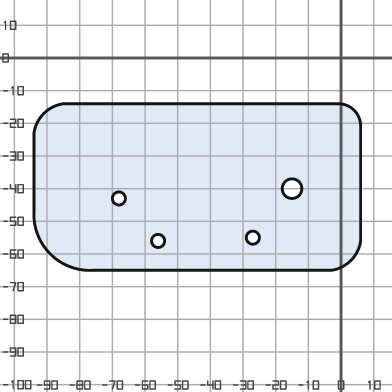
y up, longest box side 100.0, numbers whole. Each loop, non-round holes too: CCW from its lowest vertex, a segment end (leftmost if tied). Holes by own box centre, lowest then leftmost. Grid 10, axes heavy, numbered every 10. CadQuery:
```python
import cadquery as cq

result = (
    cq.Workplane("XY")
    .moveTo(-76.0, -65.0)
    .lineTo(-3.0, -65.0)
    .threePointArc((3.0, -62.0), (6.0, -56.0))
    .lineTo(6.0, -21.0)
    .threePointArc((4.0, -16.0), (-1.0, -14.0))
    .lineTo(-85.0, -14.0)
    .threePointArc((-91.0, -17.0), (-94.0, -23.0))
    .lineTo(-94.0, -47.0)
    .threePointArc((-89.0, -60.0), (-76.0, -65.0))
    .close()
    .moveTo(-56.0, -56.0)
    .circle(2.0)
    .moveTo(-27.0, -55.0)
    .circle(2.0)
    .moveTo(-68.0, -43.0)
    .circle(2.0)
    .moveTo(-15.0, -40.0)
    .circle(3.0)
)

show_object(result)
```